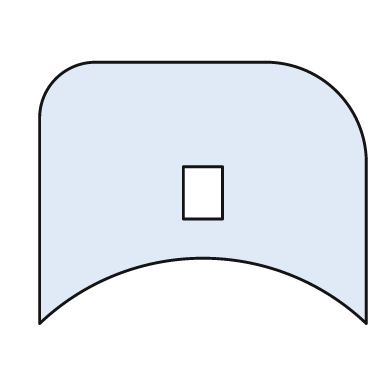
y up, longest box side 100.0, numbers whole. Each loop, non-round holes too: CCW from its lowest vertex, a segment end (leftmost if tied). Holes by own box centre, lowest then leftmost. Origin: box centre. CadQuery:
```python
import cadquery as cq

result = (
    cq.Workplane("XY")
    .moveTo(-50.0, -40.0)
    .threePointArc((0.0, -20.0), (50.0, -40.0))
    .lineTo(50.0, 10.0)
    .threePointArc((41.0, 31.0), (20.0, 40.0))
    .lineTo(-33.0, 40.0)
    .threePointArc((-45.0, 35.0), (-50.0, 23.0))
    .close()
    .moveTo(-6.0, -8.0)
    .lineTo(6.0, -8.0)
    .lineTo(6.0, 8.0)
    .lineTo(-6.0, 8.0)
    .close()
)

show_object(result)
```